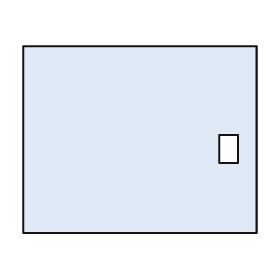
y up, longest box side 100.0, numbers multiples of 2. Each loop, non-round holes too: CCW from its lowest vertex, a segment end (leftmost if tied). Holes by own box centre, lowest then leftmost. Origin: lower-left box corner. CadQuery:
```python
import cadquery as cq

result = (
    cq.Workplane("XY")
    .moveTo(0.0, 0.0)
    .lineTo(100.0, 0.0)
    .lineTo(100.0, 80.0)
    .lineTo(0.0, 80.0)
    .close()
    .moveTo(84.0, 30.0)
    .lineTo(92.0, 30.0)
    .lineTo(92.0, 42.0)
    .lineTo(84.0, 42.0)
    .close()
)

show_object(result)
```